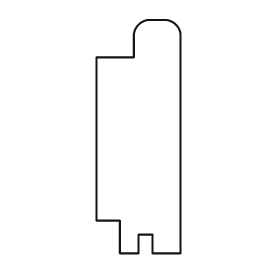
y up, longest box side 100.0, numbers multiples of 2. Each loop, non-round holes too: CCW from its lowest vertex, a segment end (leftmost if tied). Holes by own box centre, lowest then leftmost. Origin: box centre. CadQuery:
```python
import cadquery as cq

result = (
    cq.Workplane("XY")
    .moveTo(-8.0, -50.0)
    .lineTo(0.0, -50.0)
    .lineTo(0.0, -42.0)
    .lineTo(6.0, -42.0)
    .lineTo(6.0, -50.0)
    .lineTo(18.0, -50.0)
    .lineTo(18.0, 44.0)
    .threePointArc((16.0, 48.0), (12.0, 50.0))
    .lineTo(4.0, 50.0)
    .threePointArc((0.0, 48.0), (-2.0, 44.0))
    .lineTo(-2.0, 34.0)
    .lineTo(-18.0, 34.0)
    .lineTo(-18.0, -36.0)
    .lineTo(-8.0, -36.0)
    .close()
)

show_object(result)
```